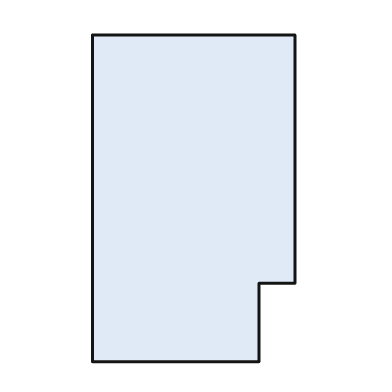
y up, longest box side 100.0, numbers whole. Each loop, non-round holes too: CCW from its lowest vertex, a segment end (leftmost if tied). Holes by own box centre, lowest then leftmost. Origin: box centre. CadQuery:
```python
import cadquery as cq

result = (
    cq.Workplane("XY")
    .moveTo(-31.0, -50.0)
    .lineTo(20.0, -50.0)
    .lineTo(20.0, -26.0)
    .lineTo(31.0, -26.0)
    .lineTo(31.0, 50.0)
    .lineTo(-31.0, 50.0)
    .close()
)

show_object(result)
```